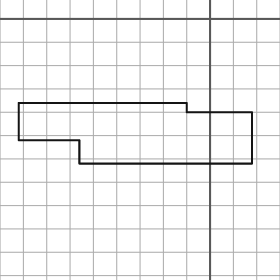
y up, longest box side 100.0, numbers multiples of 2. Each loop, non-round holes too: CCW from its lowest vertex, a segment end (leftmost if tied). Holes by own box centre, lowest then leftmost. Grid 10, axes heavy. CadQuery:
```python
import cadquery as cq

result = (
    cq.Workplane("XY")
    .moveTo(-56.0, -62.0)
    .lineTo(18.0, -62.0)
    .lineTo(18.0, -40.0)
    .lineTo(-10.0, -40.0)
    .lineTo(-10.0, -36.0)
    .lineTo(-82.0, -36.0)
    .lineTo(-82.0, -52.0)
    .lineTo(-56.0, -52.0)
    .close()
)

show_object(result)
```